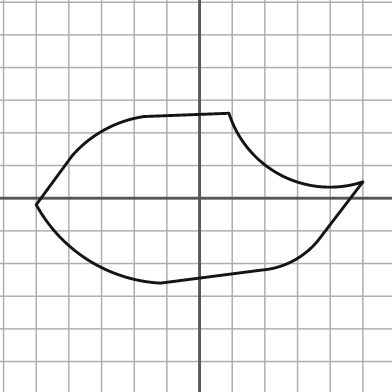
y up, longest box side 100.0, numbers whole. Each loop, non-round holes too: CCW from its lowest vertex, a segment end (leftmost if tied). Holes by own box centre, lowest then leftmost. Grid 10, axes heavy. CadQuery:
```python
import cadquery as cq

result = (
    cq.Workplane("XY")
    .moveTo(-12.0, -26.0)
    .lineTo(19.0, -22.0)
    .threePointArc((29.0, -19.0), (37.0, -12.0))
    .lineTo(50.0, 5.0)
    .threePointArc((25.0, 7.0), (9.0, 26.0))
    .lineTo(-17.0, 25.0)
    .threePointArc((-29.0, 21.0), (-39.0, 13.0))
    .lineTo(-50.0, -2.0)
    .threePointArc((-34.0, -19.0), (-12.0, -26.0))
    .close()
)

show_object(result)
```